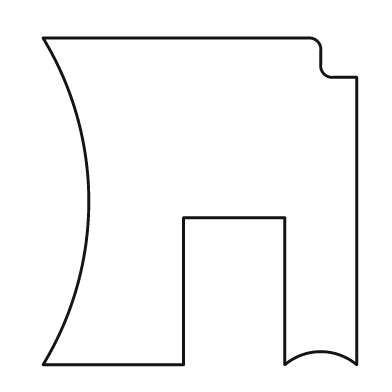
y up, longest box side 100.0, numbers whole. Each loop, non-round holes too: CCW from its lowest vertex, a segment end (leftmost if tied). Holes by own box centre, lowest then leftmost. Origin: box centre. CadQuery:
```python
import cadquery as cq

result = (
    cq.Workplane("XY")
    .moveTo(-48.0, -50.0)
    .lineTo(-5.0, -50.0)
    .lineTo(-5.0, -5.0)
    .lineTo(26.0, -5.0)
    .lineTo(26.0, -50.0)
    .threePointArc((37.0, -46.0), (48.0, -50.0))
    .lineTo(48.0, 38.0)
    .lineTo(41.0, 38.0)
    .threePointArc((38.0, 39.0), (37.0, 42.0))
    .lineTo(37.0, 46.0)
    .threePointArc((36.0, 49.0), (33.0, 50.0))
    .lineTo(-48.0, 50.0)
    .threePointArc((-34.0, 0.0), (-48.0, -50.0))
    .close()
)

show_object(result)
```